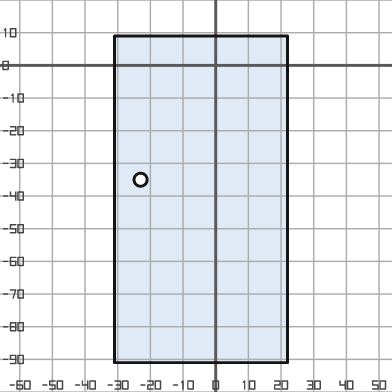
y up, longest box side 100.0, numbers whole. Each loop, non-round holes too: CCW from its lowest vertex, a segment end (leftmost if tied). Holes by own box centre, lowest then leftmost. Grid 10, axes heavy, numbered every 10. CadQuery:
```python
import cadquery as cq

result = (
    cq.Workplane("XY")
    .moveTo(-31.0, -91.0)
    .lineTo(22.0, -91.0)
    .lineTo(22.0, 9.0)
    .lineTo(-31.0, 9.0)
    .close()
    .moveTo(-23.0, -35.0)
    .circle(2.0)
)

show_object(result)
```